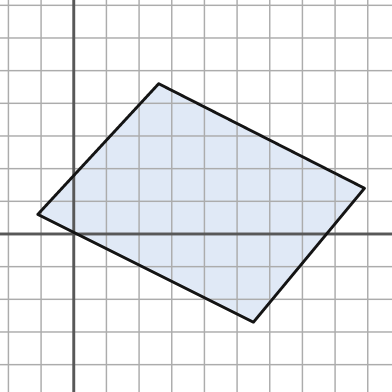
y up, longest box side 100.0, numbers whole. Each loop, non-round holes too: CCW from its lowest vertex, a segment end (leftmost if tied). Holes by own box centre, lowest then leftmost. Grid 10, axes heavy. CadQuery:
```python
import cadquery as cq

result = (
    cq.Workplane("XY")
    .moveTo(55.0, -27.0)
    .lineTo(89.0, 14.0)
    .lineTo(26.0, 46.0)
    .lineTo(-11.0, 6.0)
    .close()
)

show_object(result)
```